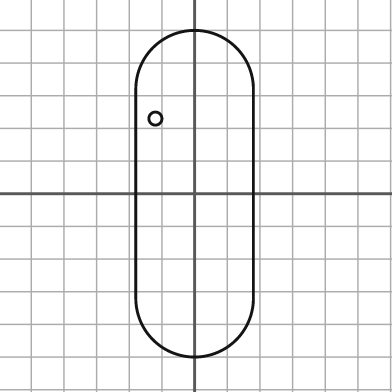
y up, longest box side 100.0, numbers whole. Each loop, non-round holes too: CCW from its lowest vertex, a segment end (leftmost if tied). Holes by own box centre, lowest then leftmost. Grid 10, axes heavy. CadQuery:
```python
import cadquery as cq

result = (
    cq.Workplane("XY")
    .moveTo(-18.0, -32.0)
    .threePointArc((0.0, -50.0), (18.0, -32.0))
    .lineTo(18.0, 32.0)
    .threePointArc((0.0, 50.0), (-18.0, 32.0))
    .close()
    .moveTo(-12.0, 23.0)
    .circle(2.0)
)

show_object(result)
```